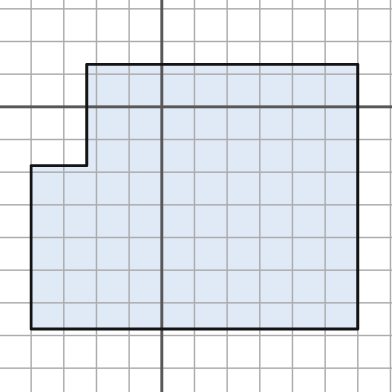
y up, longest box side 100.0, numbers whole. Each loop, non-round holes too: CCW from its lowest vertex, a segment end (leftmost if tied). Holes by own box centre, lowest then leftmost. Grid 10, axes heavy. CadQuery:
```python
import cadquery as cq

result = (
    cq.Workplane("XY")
    .moveTo(-40.0, -68.0)
    .lineTo(60.0, -68.0)
    .lineTo(60.0, 13.0)
    .lineTo(-23.0, 13.0)
    .lineTo(-23.0, -18.0)
    .lineTo(-40.0, -18.0)
    .close()
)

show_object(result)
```